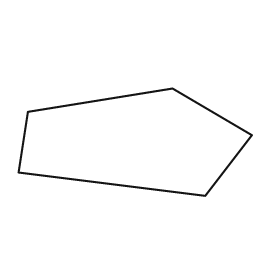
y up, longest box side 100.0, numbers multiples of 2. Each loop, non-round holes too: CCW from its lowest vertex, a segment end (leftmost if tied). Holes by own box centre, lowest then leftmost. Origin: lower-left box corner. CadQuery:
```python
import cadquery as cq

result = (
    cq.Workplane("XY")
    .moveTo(80.0, 0.0)
    .lineTo(100.0, 26.0)
    .lineTo(66.0, 46.0)
    .lineTo(4.0, 36.0)
    .lineTo(0.0, 10.0)
    .close()
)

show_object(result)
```